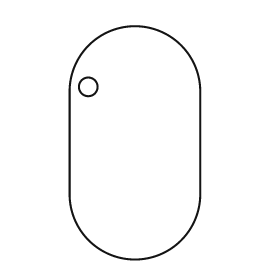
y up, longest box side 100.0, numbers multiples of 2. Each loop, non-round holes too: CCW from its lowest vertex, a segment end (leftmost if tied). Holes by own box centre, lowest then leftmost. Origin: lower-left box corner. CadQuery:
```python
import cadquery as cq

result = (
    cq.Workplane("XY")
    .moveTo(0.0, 28.0)
    .threePointArc((28.0, 0.0), (56.0, 28.0))
    .lineTo(56.0, 72.0)
    .threePointArc((28.0, 100.0), (0.0, 72.0))
    .close()
    .moveTo(8.0, 74.0)
    .circle(4.0)
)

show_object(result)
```